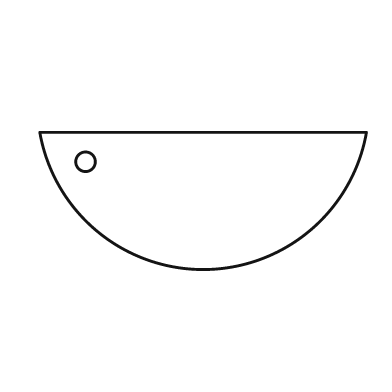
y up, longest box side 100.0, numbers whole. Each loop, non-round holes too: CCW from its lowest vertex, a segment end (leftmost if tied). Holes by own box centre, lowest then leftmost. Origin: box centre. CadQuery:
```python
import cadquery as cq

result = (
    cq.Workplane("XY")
    .moveTo(-50.0, 21.0)
    .threePointArc((0.0, -21.0), (50.0, 21.0))
    .close()
    .moveTo(-36.0, 12.0)
    .circle(3.0)
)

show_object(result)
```